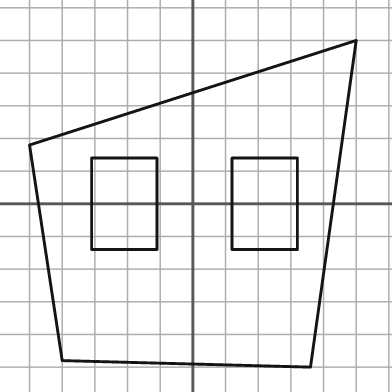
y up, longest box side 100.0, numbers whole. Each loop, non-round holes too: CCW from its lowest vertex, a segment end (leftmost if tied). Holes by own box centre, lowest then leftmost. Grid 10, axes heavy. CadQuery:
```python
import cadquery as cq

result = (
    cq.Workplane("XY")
    .moveTo(36.0, -50.0)
    .lineTo(50.0, 50.0)
    .lineTo(-50.0, 18.0)
    .lineTo(-40.0, -48.0)
    .close()
    .moveTo(-31.0, -14.0)
    .lineTo(-11.0, -14.0)
    .lineTo(-11.0, 14.0)
    .lineTo(-31.0, 14.0)
    .close()
    .moveTo(12.0, -14.0)
    .lineTo(32.0, -14.0)
    .lineTo(32.0, 14.0)
    .lineTo(12.0, 14.0)
    .close()
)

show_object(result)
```